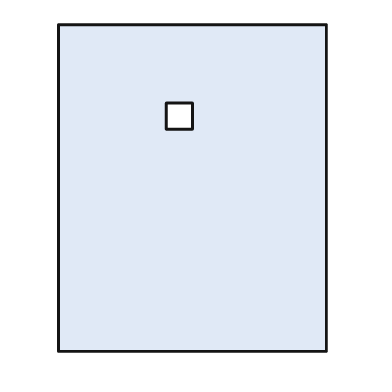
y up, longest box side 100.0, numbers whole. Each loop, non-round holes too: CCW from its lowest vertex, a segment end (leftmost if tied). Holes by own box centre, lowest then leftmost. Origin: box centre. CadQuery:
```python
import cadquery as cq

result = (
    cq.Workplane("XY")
    .moveTo(-41.0, -50.0)
    .lineTo(41.0, -50.0)
    .lineTo(41.0, 50.0)
    .lineTo(-41.0, 50.0)
    .close()
    .moveTo(-8.0, 18.0)
    .lineTo(0.0, 18.0)
    .lineTo(0.0, 26.0)
    .lineTo(-8.0, 26.0)
    .close()
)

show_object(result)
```